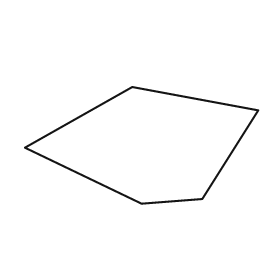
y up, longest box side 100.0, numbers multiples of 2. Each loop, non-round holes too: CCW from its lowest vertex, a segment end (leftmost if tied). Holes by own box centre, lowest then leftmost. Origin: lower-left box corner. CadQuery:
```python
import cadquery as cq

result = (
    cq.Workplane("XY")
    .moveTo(50.0, 0.0)
    .lineTo(76.0, 2.0)
    .lineTo(100.0, 40.0)
    .lineTo(46.0, 50.0)
    .lineTo(0.0, 24.0)
    .close()
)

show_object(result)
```